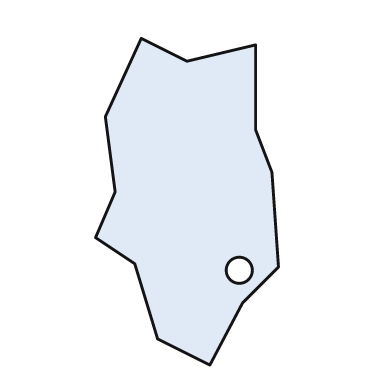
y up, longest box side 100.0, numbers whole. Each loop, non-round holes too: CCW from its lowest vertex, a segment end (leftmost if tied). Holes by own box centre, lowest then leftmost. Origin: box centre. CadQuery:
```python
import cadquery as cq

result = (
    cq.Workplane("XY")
    .moveTo(7.0, -50.0)
    .lineTo(17.0, -31.0)
    .lineTo(28.0, -20.0)
    .lineTo(26.0, 9.0)
    .lineTo(21.0, 22.0)
    .lineTo(21.0, 48.0)
    .lineTo(0.0, 43.0)
    .lineTo(-14.0, 50.0)
    .lineTo(-25.0, 26.0)
    .lineTo(-22.0, 3.0)
    .lineTo(-28.0, -11.0)
    .lineTo(-16.0, -19.0)
    .lineTo(-9.0, -42.0)
    .close()
    .moveTo(16.0, -21.0)
    .circle(4.0)
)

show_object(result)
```